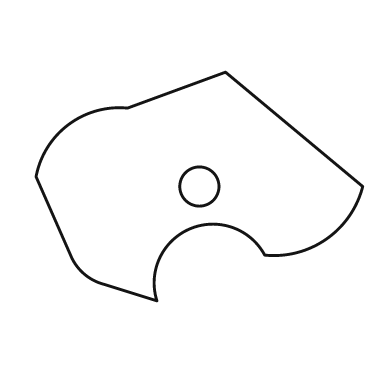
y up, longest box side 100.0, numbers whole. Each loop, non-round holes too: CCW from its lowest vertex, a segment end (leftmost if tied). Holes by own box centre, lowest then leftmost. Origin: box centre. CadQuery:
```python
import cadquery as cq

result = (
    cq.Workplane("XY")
    .moveTo(-13.0, -35.0)
    .threePointArc((-3.0, -13.0), (20.0, -21.0))
    .threePointArc((39.0, -16.0), (50.0, 0.0))
    .lineTo(8.0, 35.0)
    .lineTo(-22.0, 24.0)
    .threePointArc((-40.0, 19.0), (-50.0, 3.0))
    .lineTo(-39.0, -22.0)
    .threePointArc((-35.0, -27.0), (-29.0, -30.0))
    .close()
    .moveTo(0.0, 0.0)
    .circle(6.0)
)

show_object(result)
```